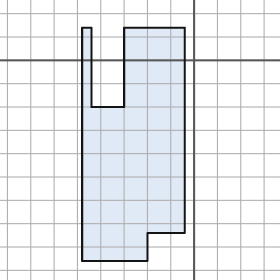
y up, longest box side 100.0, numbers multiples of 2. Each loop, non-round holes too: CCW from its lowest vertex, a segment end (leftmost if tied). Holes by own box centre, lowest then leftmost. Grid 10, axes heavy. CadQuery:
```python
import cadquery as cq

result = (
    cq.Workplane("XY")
    .moveTo(-48.0, -86.0)
    .lineTo(-20.0, -86.0)
    .lineTo(-20.0, -74.0)
    .lineTo(-4.0, -74.0)
    .lineTo(-4.0, 14.0)
    .lineTo(-30.0, 14.0)
    .lineTo(-30.0, -20.0)
    .lineTo(-44.0, -20.0)
    .lineTo(-44.0, 14.0)
    .lineTo(-48.0, 14.0)
    .close()
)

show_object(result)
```